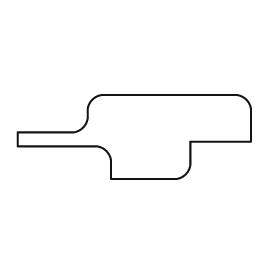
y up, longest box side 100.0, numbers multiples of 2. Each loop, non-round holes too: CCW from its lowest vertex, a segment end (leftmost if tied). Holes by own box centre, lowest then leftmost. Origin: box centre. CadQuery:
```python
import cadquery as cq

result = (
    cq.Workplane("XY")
    .moveTo(-10.0, -18.0)
    .lineTo(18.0, -18.0)
    .threePointArc((22.0, -16.0), (24.0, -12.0))
    .lineTo(24.0, -2.0)
    .lineTo(50.0, -2.0)
    .lineTo(50.0, 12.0)
    .threePointArc((48.0, 16.0), (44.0, 18.0))
    .lineTo(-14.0, 18.0)
    .threePointArc((-18.0, 16.0), (-20.0, 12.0))
    .lineTo(-20.0, 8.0)
    .threePointArc((-22.0, 4.0), (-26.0, 2.0))
    .lineTo(-50.0, 2.0)
    .lineTo(-50.0, -4.0)
    .lineTo(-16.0, -4.0)
    .threePointArc((-12.0, -6.0), (-10.0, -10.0))
    .close()
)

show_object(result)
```